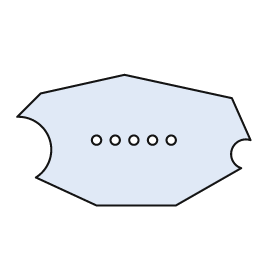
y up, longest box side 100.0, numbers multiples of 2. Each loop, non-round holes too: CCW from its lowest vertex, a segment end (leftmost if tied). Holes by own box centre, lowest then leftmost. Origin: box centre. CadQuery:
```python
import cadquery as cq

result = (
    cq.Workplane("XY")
    .moveTo(-16.0, -28.0)
    .lineTo(18.0, -28.0)
    .lineTo(46.0, -12.0)
    .threePointArc((42.0, -4.0), (50.0, 0.0))
    .lineTo(42.0, 18.0)
    .lineTo(-4.0, 28.0)
    .lineTo(-40.0, 20.0)
    .lineTo(-50.0, 10.0)
    .threePointArc((-36.0, 0.0), (-42.0, -16.0))
    .close()
    .moveTo(-16.0, 0.0)
    .circle(2.0)
    .moveTo(-8.0, 0.0)
    .circle(2.0)
    .moveTo(0.0, 0.0)
    .circle(2.0)
    .moveTo(8.0, 0.0)
    .circle(2.0)
    .moveTo(16.0, 0.0)
    .circle(2.0)
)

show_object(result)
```